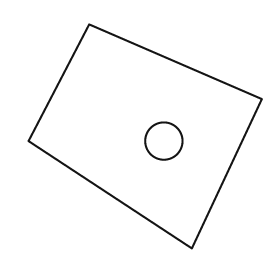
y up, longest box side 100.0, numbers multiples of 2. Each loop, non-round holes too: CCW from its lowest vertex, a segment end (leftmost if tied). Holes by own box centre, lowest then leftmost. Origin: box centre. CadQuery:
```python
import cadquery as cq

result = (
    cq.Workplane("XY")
    .moveTo(20.0, -48.0)
    .lineTo(50.0, 16.0)
    .lineTo(-24.0, 48.0)
    .lineTo(-50.0, -2.0)
    .close()
    .moveTo(8.0, -2.0)
    .circle(8.0)
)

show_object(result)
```